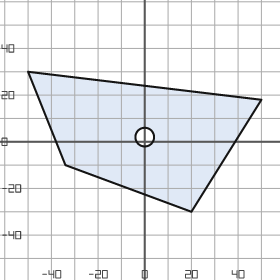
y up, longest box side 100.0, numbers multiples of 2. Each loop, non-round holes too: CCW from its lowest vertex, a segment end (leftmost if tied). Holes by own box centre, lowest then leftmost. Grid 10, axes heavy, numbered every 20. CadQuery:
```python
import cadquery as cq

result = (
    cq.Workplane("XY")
    .moveTo(20.0, -30.0)
    .lineTo(50.0, 18.0)
    .lineTo(-50.0, 30.0)
    .lineTo(-34.0, -10.0)
    .close()
    .moveTo(0.0, 2.0)
    .circle(4.0)
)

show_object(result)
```